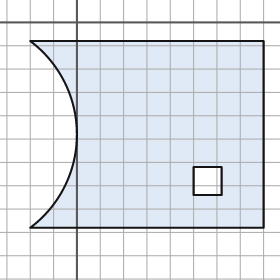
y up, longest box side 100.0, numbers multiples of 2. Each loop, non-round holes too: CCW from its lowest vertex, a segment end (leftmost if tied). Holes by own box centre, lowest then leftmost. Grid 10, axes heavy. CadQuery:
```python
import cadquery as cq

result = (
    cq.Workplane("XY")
    .moveTo(-20.0, -88.0)
    .lineTo(80.0, -88.0)
    .lineTo(80.0, -8.0)
    .lineTo(-20.0, -8.0)
    .threePointArc((0.0, -48.0), (-20.0, -88.0))
    .close()
    .moveTo(50.0, -74.0)
    .lineTo(62.0, -74.0)
    .lineTo(62.0, -62.0)
    .lineTo(50.0, -62.0)
    .close()
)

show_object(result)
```